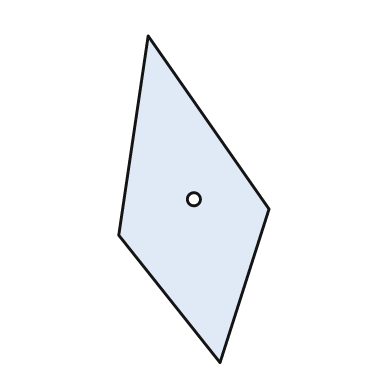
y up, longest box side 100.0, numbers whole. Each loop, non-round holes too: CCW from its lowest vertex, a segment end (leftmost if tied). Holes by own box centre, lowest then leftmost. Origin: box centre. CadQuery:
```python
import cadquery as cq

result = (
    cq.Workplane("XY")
    .moveTo(8.0, -50.0)
    .lineTo(23.0, -3.0)
    .lineTo(-14.0, 50.0)
    .lineTo(-23.0, -11.0)
    .close()
    .moveTo(0.0, 0.0)
    .circle(2.0)
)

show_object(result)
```